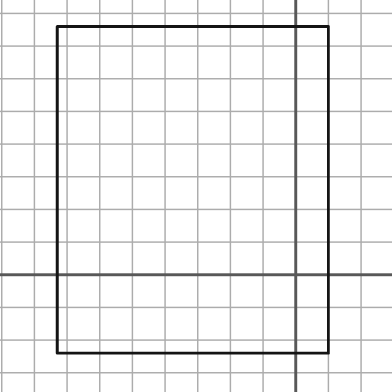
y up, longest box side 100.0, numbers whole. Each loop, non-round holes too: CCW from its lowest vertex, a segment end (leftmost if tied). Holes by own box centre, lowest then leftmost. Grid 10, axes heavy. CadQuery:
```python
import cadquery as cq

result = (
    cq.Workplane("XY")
    .moveTo(-73.0, -24.0)
    .lineTo(10.0, -24.0)
    .lineTo(10.0, 76.0)
    .lineTo(-73.0, 76.0)
    .close()
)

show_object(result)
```